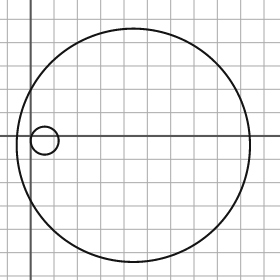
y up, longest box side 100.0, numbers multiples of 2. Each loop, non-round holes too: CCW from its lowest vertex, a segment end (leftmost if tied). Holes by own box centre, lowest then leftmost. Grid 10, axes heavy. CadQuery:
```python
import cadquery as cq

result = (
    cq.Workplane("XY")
    .moveTo(44.0, -4.0)
    .circle(50.0)
    .moveTo(6.0, -2.0)
    .circle(6.0)
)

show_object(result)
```